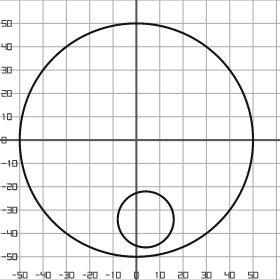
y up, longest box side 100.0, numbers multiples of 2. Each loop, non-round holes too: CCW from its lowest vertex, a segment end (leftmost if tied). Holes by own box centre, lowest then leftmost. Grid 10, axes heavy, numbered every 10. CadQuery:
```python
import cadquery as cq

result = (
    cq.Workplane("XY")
    .moveTo(0.0, 0.0)
    .circle(50.0)
    .moveTo(4.0, -34.0)
    .circle(12.0)
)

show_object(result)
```